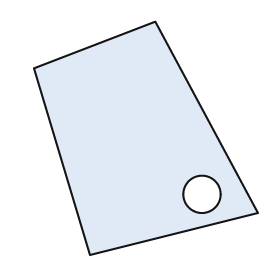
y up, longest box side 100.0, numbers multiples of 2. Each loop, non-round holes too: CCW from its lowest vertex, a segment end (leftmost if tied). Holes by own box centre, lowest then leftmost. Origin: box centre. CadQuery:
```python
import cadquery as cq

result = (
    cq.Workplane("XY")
    .moveTo(-24.0, -50.0)
    .lineTo(48.0, -32.0)
    .lineTo(4.0, 50.0)
    .lineTo(-48.0, 30.0)
    .close()
    .moveTo(24.0, -24.0)
    .circle(8.0)
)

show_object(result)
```